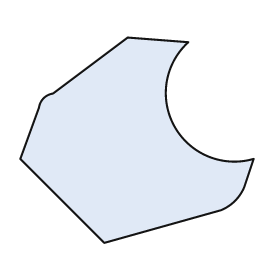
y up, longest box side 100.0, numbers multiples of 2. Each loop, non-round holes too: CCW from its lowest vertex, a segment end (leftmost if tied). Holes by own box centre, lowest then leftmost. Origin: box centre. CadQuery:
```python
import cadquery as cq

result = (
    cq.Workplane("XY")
    .moveTo(-14.0, -44.0)
    .lineTo(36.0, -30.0)
    .threePointArc((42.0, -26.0), (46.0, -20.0))
    .lineTo(50.0, -8.0)
    .threePointArc((16.0, 6.0), (22.0, 42.0))
    .lineTo(-4.0, 44.0)
    .lineTo(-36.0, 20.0)
    .threePointArc((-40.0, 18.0), (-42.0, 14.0))
    .lineTo(-50.0, -8.0)
    .close()
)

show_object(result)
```